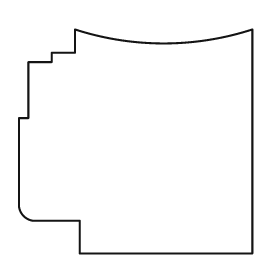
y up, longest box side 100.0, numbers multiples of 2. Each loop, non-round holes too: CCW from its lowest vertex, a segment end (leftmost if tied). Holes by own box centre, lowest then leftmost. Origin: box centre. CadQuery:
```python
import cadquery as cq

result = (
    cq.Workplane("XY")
    .moveTo(-24.0, -48.0)
    .lineTo(50.0, -48.0)
    .lineTo(50.0, 48.0)
    .threePointArc((12.0, 42.0), (-26.0, 48.0))
    .lineTo(-26.0, 38.0)
    .lineTo(-36.0, 38.0)
    .lineTo(-36.0, 34.0)
    .lineTo(-46.0, 34.0)
    .lineTo(-46.0, 10.0)
    .lineTo(-50.0, 10.0)
    .lineTo(-50.0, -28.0)
    .threePointArc((-48.0, -32.0), (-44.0, -34.0))
    .lineTo(-24.0, -34.0)
    .close()
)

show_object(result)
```